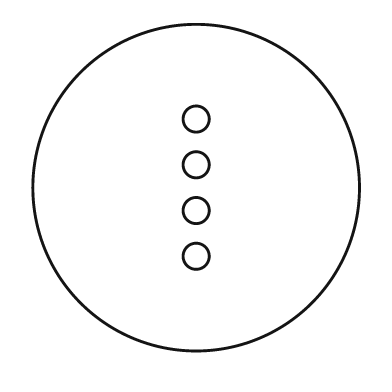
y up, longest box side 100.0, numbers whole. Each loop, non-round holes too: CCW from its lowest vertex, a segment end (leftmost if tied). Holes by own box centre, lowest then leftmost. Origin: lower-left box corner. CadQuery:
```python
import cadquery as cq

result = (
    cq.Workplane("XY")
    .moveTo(50.0, 50.0)
    .circle(50.0)
    .moveTo(50.0, 29.0)
    .circle(4.0)
    .moveTo(50.0, 43.0)
    .circle(4.0)
    .moveTo(50.0, 57.0)
    .circle(4.0)
    .moveTo(50.0, 71.0)
    .circle(4.0)
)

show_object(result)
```